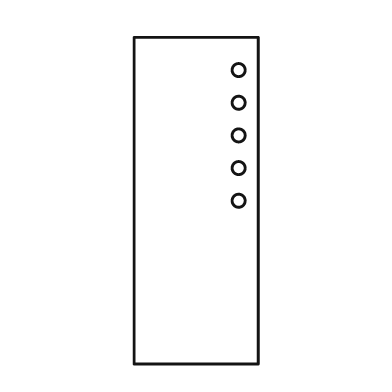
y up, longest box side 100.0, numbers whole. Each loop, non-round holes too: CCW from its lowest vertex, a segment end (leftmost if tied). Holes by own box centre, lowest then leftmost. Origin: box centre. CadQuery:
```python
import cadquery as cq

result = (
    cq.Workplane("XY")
    .moveTo(-19.0, -50.0)
    .lineTo(19.0, -50.0)
    .lineTo(19.0, 50.0)
    .lineTo(-19.0, 50.0)
    .close()
    .moveTo(13.0, 0.0)
    .circle(2.0)
    .moveTo(13.0, 10.0)
    .circle(2.0)
    .moveTo(13.0, 20.0)
    .circle(2.0)
    .moveTo(13.0, 30.0)
    .circle(2.0)
    .moveTo(13.0, 40.0)
    .circle(2.0)
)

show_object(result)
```